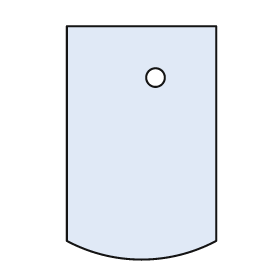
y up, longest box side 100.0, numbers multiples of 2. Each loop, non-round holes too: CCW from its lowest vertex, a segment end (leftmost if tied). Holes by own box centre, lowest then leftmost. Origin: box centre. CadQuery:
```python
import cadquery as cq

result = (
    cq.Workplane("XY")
    .moveTo(-32.0, -42.0)
    .threePointArc((0.0, -50.0), (32.0, -42.0))
    .lineTo(32.0, 50.0)
    .lineTo(-32.0, 50.0)
    .close()
    .moveTo(6.0, 28.0)
    .circle(4.0)
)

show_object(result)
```